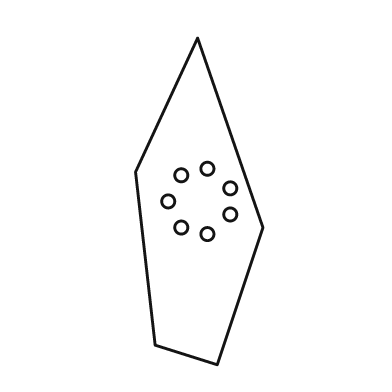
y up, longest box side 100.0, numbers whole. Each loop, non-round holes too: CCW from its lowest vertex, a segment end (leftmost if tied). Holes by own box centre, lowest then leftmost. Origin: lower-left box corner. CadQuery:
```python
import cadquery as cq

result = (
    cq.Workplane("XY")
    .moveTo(25.0, 0.0)
    .lineTo(39.0, 42.0)
    .lineTo(19.0, 100.0)
    .lineTo(0.0, 59.0)
    .lineTo(6.0, 6.0)
    .close()
    .moveTo(22.0, 40.0)
    .circle(2.0)
    .moveTo(14.0, 42.0)
    .circle(2.0)
    .moveTo(29.0, 46.0)
    .circle(2.0)
    .moveTo(10.0, 50.0)
    .circle(2.0)
    .moveTo(29.0, 54.0)
    .circle(2.0)
    .moveTo(14.0, 58.0)
    .circle(2.0)
    .moveTo(22.0, 60.0)
    .circle(2.0)
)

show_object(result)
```